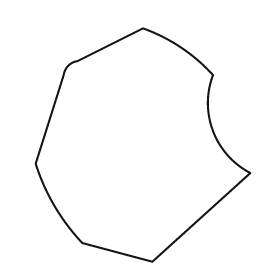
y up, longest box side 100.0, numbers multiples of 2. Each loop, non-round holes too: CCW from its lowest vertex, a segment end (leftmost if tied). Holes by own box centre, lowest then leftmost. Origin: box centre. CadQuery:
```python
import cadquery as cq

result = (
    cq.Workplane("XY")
    .moveTo(4.0, -50.0)
    .lineTo(46.0, -12.0)
    .threePointArc((30.0, 6.0), (30.0, 30.0))
    .threePointArc((16.0, 42.0), (0.0, 50.0))
    .lineTo(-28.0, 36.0)
    .threePointArc((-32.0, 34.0), (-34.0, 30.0))
    .lineTo(-46.0, -8.0)
    .threePointArc((-38.0, -26.0), (-26.0, -42.0))
    .close()
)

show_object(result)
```